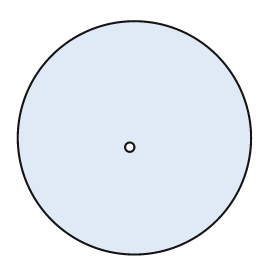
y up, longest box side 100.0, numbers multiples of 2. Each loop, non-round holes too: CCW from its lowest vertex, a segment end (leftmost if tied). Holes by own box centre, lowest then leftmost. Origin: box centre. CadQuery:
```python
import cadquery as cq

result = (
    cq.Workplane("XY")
    .moveTo(0.0, 0.0)
    .circle(50.0)
    .moveTo(-2.0, -4.0)
    .circle(2.0)
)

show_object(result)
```